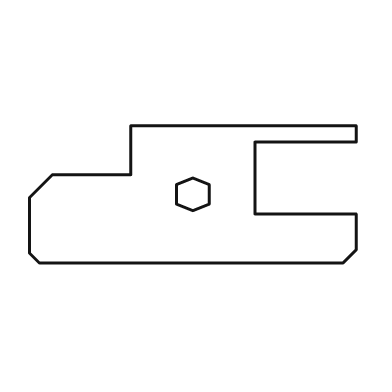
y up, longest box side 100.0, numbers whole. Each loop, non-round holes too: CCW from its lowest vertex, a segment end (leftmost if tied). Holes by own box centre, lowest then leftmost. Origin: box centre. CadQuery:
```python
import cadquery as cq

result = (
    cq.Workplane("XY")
    .moveTo(-47.0, -21.0)
    .lineTo(46.0, -21.0)
    .lineTo(50.0, -17.0)
    .lineTo(50.0, -6.0)
    .lineTo(19.0, -6.0)
    .lineTo(19.0, 16.0)
    .lineTo(50.0, 16.0)
    .lineTo(50.0, 21.0)
    .lineTo(-19.0, 21.0)
    .lineTo(-19.0, 6.0)
    .lineTo(-43.0, 6.0)
    .lineTo(-50.0, -1.0)
    .lineTo(-50.0, -18.0)
    .close()
    .moveTo(0.0, -5.0)
    .lineTo(5.0, -3.0)
    .lineTo(5.0, 3.0)
    .lineTo(0.0, 5.0)
    .lineTo(-5.0, 3.0)
    .lineTo(-5.0, -3.0)
    .close()
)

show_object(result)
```